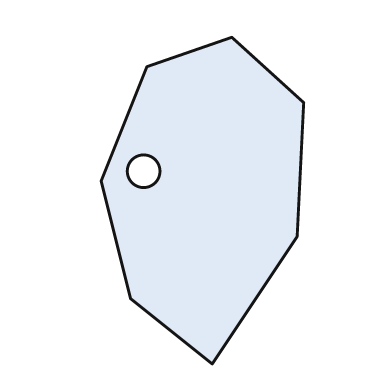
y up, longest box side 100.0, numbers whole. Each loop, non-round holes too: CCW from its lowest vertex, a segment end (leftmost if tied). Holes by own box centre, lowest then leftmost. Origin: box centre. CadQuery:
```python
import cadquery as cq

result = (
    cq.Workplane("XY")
    .moveTo(3.0, -50.0)
    .lineTo(29.0, -11.0)
    .lineTo(31.0, 30.0)
    .lineTo(9.0, 50.0)
    .lineTo(-17.0, 41.0)
    .lineTo(-31.0, 6.0)
    .lineTo(-22.0, -30.0)
    .close()
    .moveTo(-18.0, 9.0)
    .circle(5.0)
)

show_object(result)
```